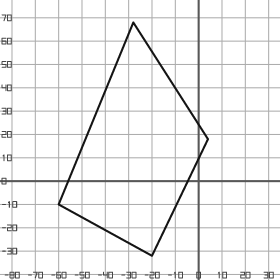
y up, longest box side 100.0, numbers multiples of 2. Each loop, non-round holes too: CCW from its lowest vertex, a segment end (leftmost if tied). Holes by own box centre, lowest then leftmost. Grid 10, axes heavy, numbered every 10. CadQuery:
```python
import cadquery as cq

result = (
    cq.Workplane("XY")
    .moveTo(-20.0, -32.0)
    .lineTo(4.0, 18.0)
    .lineTo(-28.0, 68.0)
    .lineTo(-60.0, -10.0)
    .close()
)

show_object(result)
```